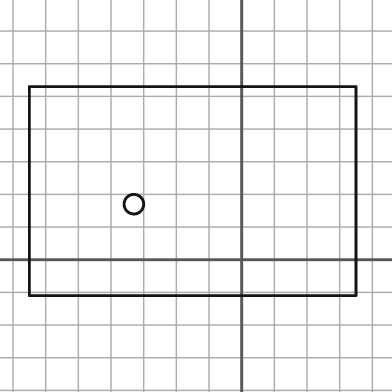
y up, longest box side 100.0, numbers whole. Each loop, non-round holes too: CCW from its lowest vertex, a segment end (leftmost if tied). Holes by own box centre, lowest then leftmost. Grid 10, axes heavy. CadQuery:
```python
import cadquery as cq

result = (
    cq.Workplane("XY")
    .moveTo(-65.0, -11.0)
    .lineTo(35.0, -11.0)
    .lineTo(35.0, 53.0)
    .lineTo(-65.0, 53.0)
    .close()
    .moveTo(-33.0, 17.0)
    .circle(3.0)
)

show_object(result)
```